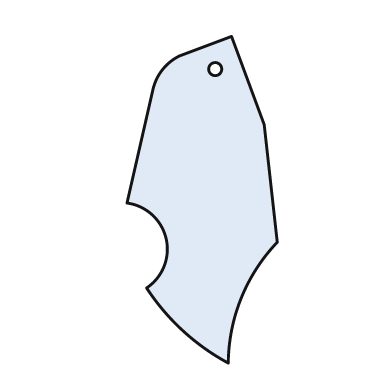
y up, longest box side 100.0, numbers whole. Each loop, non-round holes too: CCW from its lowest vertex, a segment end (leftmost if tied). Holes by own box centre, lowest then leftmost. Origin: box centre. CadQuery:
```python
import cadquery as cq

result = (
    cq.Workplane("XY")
    .moveTo(8.0, -50.0)
    .threePointArc((12.0, -30.0), (23.0, -13.0))
    .lineTo(19.0, 23.0)
    .lineTo(9.0, 50.0)
    .lineTo(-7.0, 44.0)
    .threePointArc((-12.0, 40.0), (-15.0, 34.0))
    .lineTo(-23.0, -1.0)
    .threePointArc((-11.0, -12.0), (-17.0, -27.0))
    .threePointArc((-6.0, -40.0), (8.0, -50.0))
    .close()
    .moveTo(4.0, 40.0)
    .circle(2.0)
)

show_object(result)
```